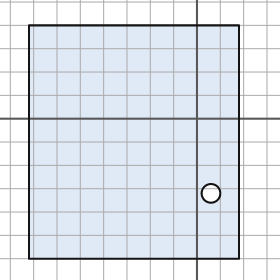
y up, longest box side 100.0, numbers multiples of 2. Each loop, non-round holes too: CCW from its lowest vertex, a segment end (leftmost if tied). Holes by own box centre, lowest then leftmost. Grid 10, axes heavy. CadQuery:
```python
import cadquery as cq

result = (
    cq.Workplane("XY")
    .moveTo(-72.0, -60.0)
    .lineTo(18.0, -60.0)
    .lineTo(18.0, 40.0)
    .lineTo(-72.0, 40.0)
    .close()
    .moveTo(6.0, -32.0)
    .circle(4.0)
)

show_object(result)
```